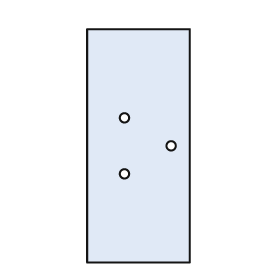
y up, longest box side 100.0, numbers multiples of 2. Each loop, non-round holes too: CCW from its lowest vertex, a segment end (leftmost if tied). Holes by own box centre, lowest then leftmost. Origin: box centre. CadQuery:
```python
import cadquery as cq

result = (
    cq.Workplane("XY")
    .moveTo(-22.0, -50.0)
    .lineTo(22.0, -50.0)
    .lineTo(22.0, 50.0)
    .lineTo(-22.0, 50.0)
    .close()
    .moveTo(-6.0, -12.0)
    .circle(2.0)
    .moveTo(14.0, 0.0)
    .circle(2.0)
    .moveTo(-6.0, 12.0)
    .circle(2.0)
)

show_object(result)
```